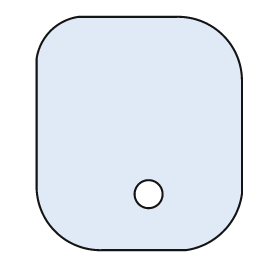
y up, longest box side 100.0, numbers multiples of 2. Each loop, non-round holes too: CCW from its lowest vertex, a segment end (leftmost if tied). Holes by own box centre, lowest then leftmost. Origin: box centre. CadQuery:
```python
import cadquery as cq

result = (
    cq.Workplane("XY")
    .moveTo(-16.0, -50.0)
    .lineTo(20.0, -50.0)
    .threePointArc((36.0, -42.0), (44.0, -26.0))
    .lineTo(44.0, 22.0)
    .threePointArc((36.0, 42.0), (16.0, 50.0))
    .lineTo(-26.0, 50.0)
    .threePointArc((-38.0, 44.0), (-44.0, 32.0))
    .lineTo(-44.0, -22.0)
    .threePointArc((-36.0, -42.0), (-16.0, -50.0))
    .close()
    .moveTo(4.0, -26.0)
    .circle(6.0)
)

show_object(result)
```